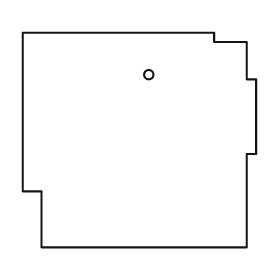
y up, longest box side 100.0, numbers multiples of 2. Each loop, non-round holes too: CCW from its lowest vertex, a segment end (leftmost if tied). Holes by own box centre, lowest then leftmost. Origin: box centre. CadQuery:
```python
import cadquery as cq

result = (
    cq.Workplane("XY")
    .moveTo(-42.0, -46.0)
    .lineTo(46.0, -46.0)
    .lineTo(46.0, -6.0)
    .lineTo(50.0, -6.0)
    .lineTo(50.0, 26.0)
    .lineTo(46.0, 26.0)
    .lineTo(46.0, 42.0)
    .lineTo(32.0, 42.0)
    .lineTo(32.0, 46.0)
    .lineTo(-50.0, 46.0)
    .lineTo(-50.0, -22.0)
    .lineTo(-42.0, -22.0)
    .close()
    .moveTo(4.0, 28.0)
    .circle(2.0)
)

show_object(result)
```